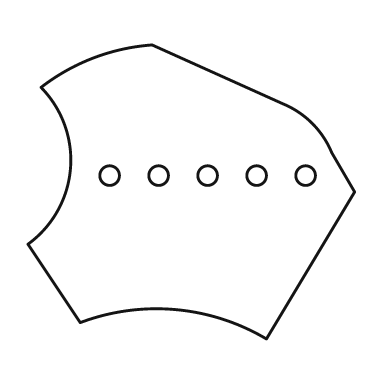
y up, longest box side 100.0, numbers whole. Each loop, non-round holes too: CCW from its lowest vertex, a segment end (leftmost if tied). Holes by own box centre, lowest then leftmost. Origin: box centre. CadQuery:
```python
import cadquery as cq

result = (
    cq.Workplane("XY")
    .moveTo(23.0, -45.0)
    .lineTo(50.0, 0.0)
    .lineTo(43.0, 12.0)
    .threePointArc((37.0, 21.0), (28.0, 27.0))
    .lineTo(-12.0, 45.0)
    .threePointArc((-30.0, 41.0), (-46.0, 32.0))
    .threePointArc((-37.0, 7.0), (-50.0, -16.0))
    .lineTo(-34.0, -40.0)
    .threePointArc((-5.0, -36.0), (23.0, -45.0))
    .close()
    .moveTo(-25.0, 5.0)
    .circle(3.0)
    .moveTo(-10.0, 5.0)
    .circle(3.0)
    .moveTo(5.0, 5.0)
    .circle(3.0)
    .moveTo(20.0, 5.0)
    .circle(3.0)
    .moveTo(35.0, 5.0)
    .circle(3.0)
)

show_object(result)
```